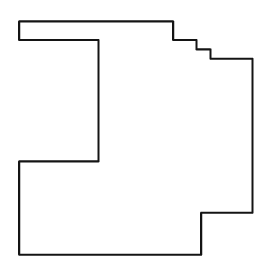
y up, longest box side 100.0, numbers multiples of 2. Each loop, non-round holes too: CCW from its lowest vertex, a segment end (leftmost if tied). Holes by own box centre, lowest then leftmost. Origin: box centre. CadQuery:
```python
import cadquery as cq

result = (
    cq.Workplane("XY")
    .moveTo(-50.0, -50.0)
    .lineTo(28.0, -50.0)
    .lineTo(28.0, -32.0)
    .lineTo(50.0, -32.0)
    .lineTo(50.0, 34.0)
    .lineTo(32.0, 34.0)
    .lineTo(32.0, 38.0)
    .lineTo(26.0, 38.0)
    .lineTo(26.0, 42.0)
    .lineTo(16.0, 42.0)
    .lineTo(16.0, 50.0)
    .lineTo(-50.0, 50.0)
    .lineTo(-50.0, 42.0)
    .lineTo(-16.0, 42.0)
    .lineTo(-16.0, -10.0)
    .lineTo(-50.0, -10.0)
    .close()
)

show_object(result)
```